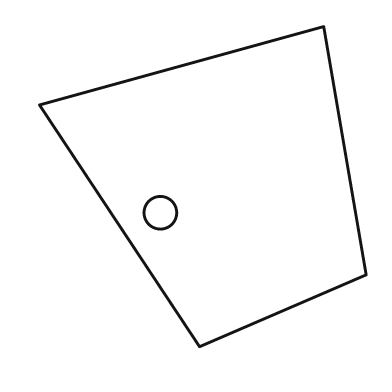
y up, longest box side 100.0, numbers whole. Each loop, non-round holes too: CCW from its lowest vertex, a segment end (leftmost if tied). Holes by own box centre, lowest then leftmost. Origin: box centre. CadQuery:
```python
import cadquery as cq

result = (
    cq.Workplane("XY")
    .moveTo(-1.0, -49.0)
    .lineTo(50.0, -27.0)
    .lineTo(37.0, 49.0)
    .lineTo(-50.0, 25.0)
    .close()
    .moveTo(-13.0, -8.0)
    .circle(5.0)
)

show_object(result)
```